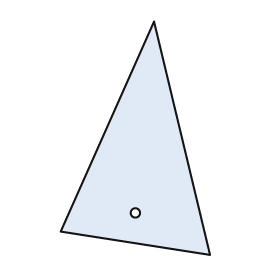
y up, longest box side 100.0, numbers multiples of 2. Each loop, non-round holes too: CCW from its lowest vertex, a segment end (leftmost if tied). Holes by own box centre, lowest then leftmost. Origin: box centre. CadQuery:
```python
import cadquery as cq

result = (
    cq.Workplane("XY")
    .moveTo(32.0, -50.0)
    .lineTo(8.0, 50.0)
    .lineTo(-32.0, -40.0)
    .close()
    .moveTo(0.0, -32.0)
    .circle(2.0)
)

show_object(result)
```